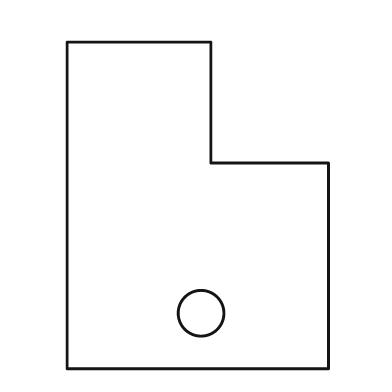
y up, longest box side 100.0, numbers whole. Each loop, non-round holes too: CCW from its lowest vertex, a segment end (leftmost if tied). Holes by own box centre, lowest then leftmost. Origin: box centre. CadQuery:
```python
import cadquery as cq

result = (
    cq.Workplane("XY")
    .moveTo(-40.0, -50.0)
    .lineTo(40.0, -50.0)
    .lineTo(40.0, 13.0)
    .lineTo(4.0, 13.0)
    .lineTo(4.0, 50.0)
    .lineTo(-40.0, 50.0)
    .close()
    .moveTo(1.0, -33.0)
    .circle(7.0)
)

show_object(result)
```